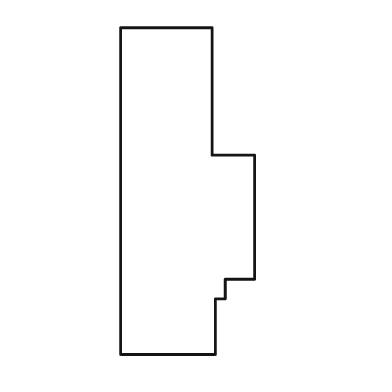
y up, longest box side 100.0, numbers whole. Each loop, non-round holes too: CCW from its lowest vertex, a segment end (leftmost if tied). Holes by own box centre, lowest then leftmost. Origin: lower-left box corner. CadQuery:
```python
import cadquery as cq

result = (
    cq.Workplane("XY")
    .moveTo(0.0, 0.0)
    .lineTo(29.0, 0.0)
    .lineTo(29.0, 17.0)
    .lineTo(32.0, 17.0)
    .lineTo(32.0, 23.0)
    .lineTo(41.0, 23.0)
    .lineTo(41.0, 61.0)
    .lineTo(28.0, 61.0)
    .lineTo(28.0, 100.0)
    .lineTo(0.0, 100.0)
    .close()
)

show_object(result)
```